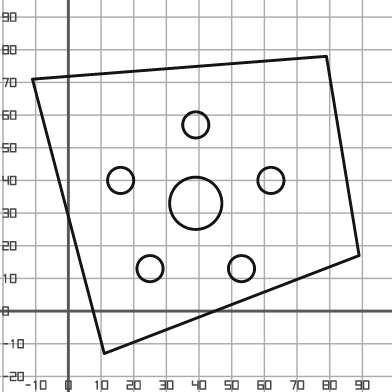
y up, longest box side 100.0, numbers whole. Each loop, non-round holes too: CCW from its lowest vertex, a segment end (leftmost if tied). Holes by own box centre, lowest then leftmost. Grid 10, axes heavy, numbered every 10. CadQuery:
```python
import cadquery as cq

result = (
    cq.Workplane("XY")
    .moveTo(11.0, -13.0)
    .lineTo(89.0, 17.0)
    .lineTo(79.0, 78.0)
    .lineTo(-11.0, 71.0)
    .close()
    .moveTo(25.0, 13.0)
    .circle(4.0)
    .moveTo(53.0, 13.0)
    .circle(4.0)
    .moveTo(39.0, 33.0)
    .circle(8.0)
    .moveTo(16.0, 40.0)
    .circle(4.0)
    .moveTo(62.0, 40.0)
    .circle(4.0)
    .moveTo(39.0, 57.0)
    .circle(4.0)
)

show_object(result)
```